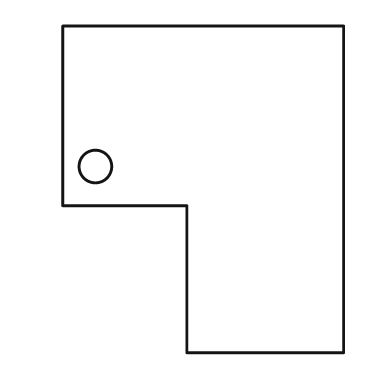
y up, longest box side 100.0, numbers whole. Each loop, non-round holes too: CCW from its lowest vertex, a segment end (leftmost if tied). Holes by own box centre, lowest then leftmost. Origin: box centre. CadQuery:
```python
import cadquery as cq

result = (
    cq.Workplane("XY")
    .moveTo(-5.0, -50.0)
    .lineTo(43.0, -50.0)
    .lineTo(43.0, 50.0)
    .lineTo(-43.0, 50.0)
    .lineTo(-43.0, -5.0)
    .lineTo(-5.0, -5.0)
    .close()
    .moveTo(-33.0, 7.0)
    .circle(5.0)
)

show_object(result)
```